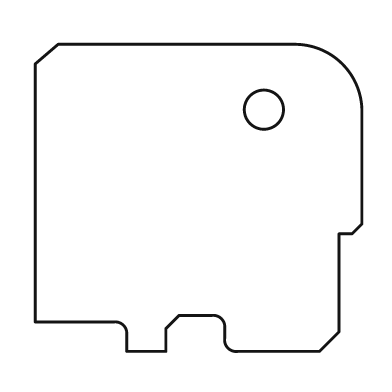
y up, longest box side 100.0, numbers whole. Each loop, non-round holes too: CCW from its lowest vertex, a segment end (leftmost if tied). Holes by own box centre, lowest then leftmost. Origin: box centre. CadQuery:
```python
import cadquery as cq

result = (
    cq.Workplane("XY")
    .moveTo(-22.0, -47.0)
    .lineTo(-10.0, -47.0)
    .lineTo(-10.0, -40.0)
    .lineTo(-6.0, -36.0)
    .lineTo(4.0, -36.0)
    .threePointArc((7.0, -37.0), (8.0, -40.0))
    .lineTo(8.0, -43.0)
    .threePointArc((9.0, -46.0), (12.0, -47.0))
    .lineTo(37.0, -47.0)
    .lineTo(43.0, -41.0)
    .lineTo(43.0, -11.0)
    .lineTo(47.0, -11.0)
    .lineTo(50.0, -8.0)
    .lineTo(50.0, 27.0)
    .threePointArc((44.0, 41.0), (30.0, 47.0))
    .lineTo(-43.0, 47.0)
    .lineTo(-50.0, 41.0)
    .lineTo(-50.0, -38.0)
    .lineTo(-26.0, -38.0)
    .threePointArc((-23.0, -39.0), (-22.0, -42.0))
    .close()
    .moveTo(20.0, 27.0)
    .circle(6.0)
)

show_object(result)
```